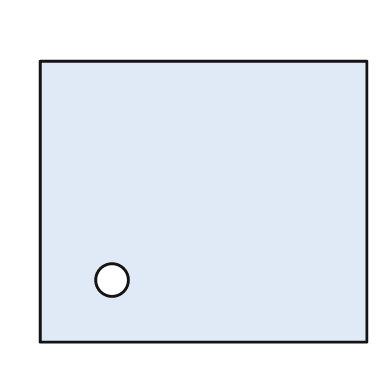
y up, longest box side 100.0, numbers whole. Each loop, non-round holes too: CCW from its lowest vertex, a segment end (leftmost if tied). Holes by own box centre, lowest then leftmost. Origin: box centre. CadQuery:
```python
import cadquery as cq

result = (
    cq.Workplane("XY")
    .moveTo(-50.0, -43.0)
    .lineTo(50.0, -43.0)
    .lineTo(50.0, 43.0)
    .lineTo(-50.0, 43.0)
    .close()
    .moveTo(-28.0, -24.0)
    .circle(5.0)
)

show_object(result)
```